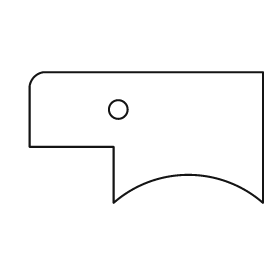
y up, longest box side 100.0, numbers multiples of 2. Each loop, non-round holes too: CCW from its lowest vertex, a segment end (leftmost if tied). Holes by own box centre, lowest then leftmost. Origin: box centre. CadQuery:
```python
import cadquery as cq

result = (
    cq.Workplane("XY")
    .moveTo(-14.0, -28.0)
    .threePointArc((18.0, -16.0), (50.0, -28.0))
    .lineTo(50.0, 28.0)
    .lineTo(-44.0, 28.0)
    .threePointArc((-48.0, 26.0), (-50.0, 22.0))
    .lineTo(-50.0, -4.0)
    .lineTo(-14.0, -4.0)
    .close()
    .moveTo(-12.0, 12.0)
    .circle(4.0)
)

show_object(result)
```